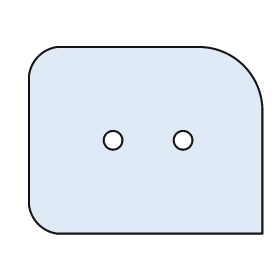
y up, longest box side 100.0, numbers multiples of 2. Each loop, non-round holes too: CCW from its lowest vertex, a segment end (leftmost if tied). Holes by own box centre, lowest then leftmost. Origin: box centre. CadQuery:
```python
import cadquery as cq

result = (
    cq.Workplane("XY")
    .moveTo(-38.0, -40.0)
    .lineTo(50.0, -40.0)
    .lineTo(50.0, 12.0)
    .threePointArc((42.0, 32.0), (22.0, 40.0))
    .lineTo(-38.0, 40.0)
    .threePointArc((-46.0, 36.0), (-50.0, 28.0))
    .lineTo(-50.0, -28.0)
    .threePointArc((-46.0, -36.0), (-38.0, -40.0))
    .close()
    .moveTo(-14.0, 0.0)
    .circle(4.0)
    .moveTo(16.0, 0.0)
    .circle(4.0)
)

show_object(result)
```